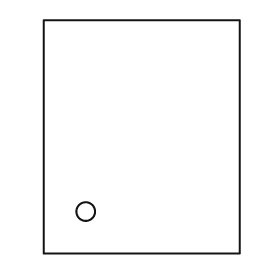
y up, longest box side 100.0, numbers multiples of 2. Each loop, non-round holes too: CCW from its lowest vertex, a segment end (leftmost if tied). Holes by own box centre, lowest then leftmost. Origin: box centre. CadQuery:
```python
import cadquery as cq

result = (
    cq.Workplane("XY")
    .moveTo(-42.0, -50.0)
    .lineTo(42.0, -50.0)
    .lineTo(42.0, 50.0)
    .lineTo(-42.0, 50.0)
    .close()
    .moveTo(-24.0, -32.0)
    .circle(4.0)
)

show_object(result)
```